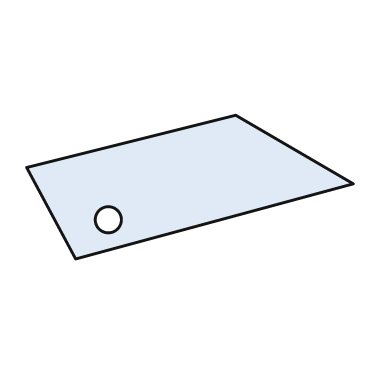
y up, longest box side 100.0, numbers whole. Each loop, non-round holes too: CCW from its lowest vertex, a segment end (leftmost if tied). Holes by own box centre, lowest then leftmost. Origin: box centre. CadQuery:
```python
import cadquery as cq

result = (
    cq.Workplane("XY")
    .moveTo(-35.0, -22.0)
    .lineTo(50.0, 1.0)
    .lineTo(14.0, 22.0)
    .lineTo(-50.0, 6.0)
    .close()
    .moveTo(-25.0, -10.0)
    .circle(4.0)
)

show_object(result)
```